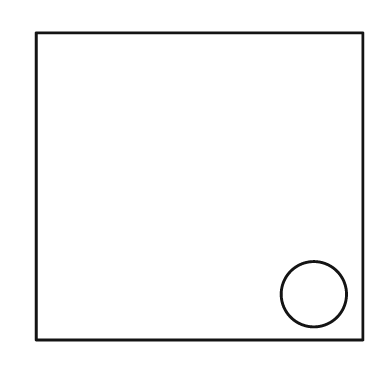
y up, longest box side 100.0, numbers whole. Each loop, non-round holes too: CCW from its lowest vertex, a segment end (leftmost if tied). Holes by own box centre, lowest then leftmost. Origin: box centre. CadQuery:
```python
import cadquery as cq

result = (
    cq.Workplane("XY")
    .moveTo(-50.0, -47.0)
    .lineTo(50.0, -47.0)
    .lineTo(50.0, 47.0)
    .lineTo(-50.0, 47.0)
    .close()
    .moveTo(35.0, -33.0)
    .circle(10.0)
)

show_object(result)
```